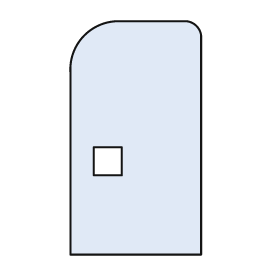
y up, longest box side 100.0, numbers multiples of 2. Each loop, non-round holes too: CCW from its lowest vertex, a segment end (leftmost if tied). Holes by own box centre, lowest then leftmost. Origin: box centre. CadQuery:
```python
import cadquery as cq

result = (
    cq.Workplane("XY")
    .moveTo(-28.0, -50.0)
    .lineTo(28.0, -50.0)
    .lineTo(28.0, 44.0)
    .threePointArc((26.0, 48.0), (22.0, 50.0))
    .lineTo(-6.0, 50.0)
    .threePointArc((-22.0, 44.0), (-28.0, 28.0))
    .close()
    .moveTo(-18.0, -16.0)
    .lineTo(-6.0, -16.0)
    .lineTo(-6.0, -4.0)
    .lineTo(-18.0, -4.0)
    .close()
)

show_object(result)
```